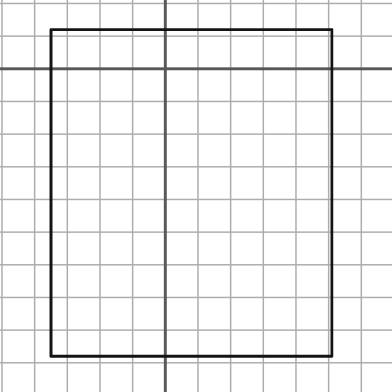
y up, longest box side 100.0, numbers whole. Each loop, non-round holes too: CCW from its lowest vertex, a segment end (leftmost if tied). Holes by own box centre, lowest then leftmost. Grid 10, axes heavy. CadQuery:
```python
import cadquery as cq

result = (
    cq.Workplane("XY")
    .moveTo(-35.0, -88.0)
    .lineTo(51.0, -88.0)
    .lineTo(51.0, 12.0)
    .lineTo(-35.0, 12.0)
    .close()
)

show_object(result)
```